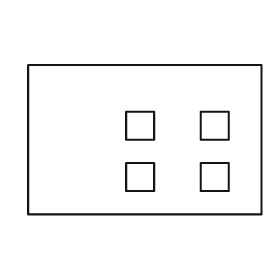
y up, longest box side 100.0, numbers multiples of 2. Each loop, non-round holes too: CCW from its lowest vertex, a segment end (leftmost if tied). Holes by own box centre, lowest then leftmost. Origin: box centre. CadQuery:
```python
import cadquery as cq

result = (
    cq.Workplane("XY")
    .moveTo(-50.0, -32.0)
    .lineTo(50.0, -32.0)
    .lineTo(50.0, 32.0)
    .lineTo(-50.0, 32.0)
    .close()
    .moveTo(-8.0, -22.0)
    .lineTo(4.0, -22.0)
    .lineTo(4.0, -10.0)
    .lineTo(-8.0, -10.0)
    .close()
    .moveTo(24.0, -22.0)
    .lineTo(36.0, -22.0)
    .lineTo(36.0, -10.0)
    .lineTo(24.0, -10.0)
    .close()
    .moveTo(-8.0, 0.0)
    .lineTo(4.0, 0.0)
    .lineTo(4.0, 12.0)
    .lineTo(-8.0, 12.0)
    .close()
    .moveTo(24.0, 0.0)
    .lineTo(36.0, 0.0)
    .lineTo(36.0, 12.0)
    .lineTo(24.0, 12.0)
    .close()
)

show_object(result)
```